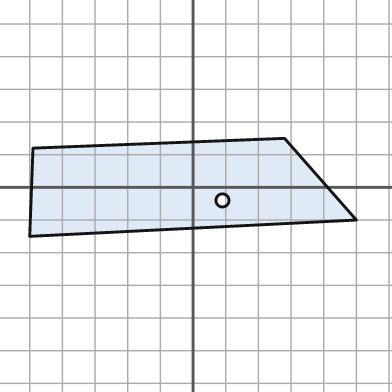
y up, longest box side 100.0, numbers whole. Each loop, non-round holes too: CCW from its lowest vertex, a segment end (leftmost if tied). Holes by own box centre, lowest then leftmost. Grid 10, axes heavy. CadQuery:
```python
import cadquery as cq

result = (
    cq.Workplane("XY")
    .moveTo(-50.0, -15.0)
    .lineTo(50.0, -10.0)
    .lineTo(28.0, 15.0)
    .lineTo(-49.0, 12.0)
    .close()
    .moveTo(9.0, -4.0)
    .circle(2.0)
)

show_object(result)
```